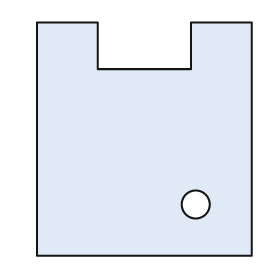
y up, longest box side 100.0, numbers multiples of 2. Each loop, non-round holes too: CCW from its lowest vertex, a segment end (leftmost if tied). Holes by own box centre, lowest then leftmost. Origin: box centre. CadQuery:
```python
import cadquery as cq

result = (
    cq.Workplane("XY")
    .moveTo(-46.0, -50.0)
    .lineTo(46.0, -50.0)
    .lineTo(46.0, 50.0)
    .lineTo(20.0, 50.0)
    .lineTo(20.0, 30.0)
    .lineTo(-20.0, 30.0)
    .lineTo(-20.0, 50.0)
    .lineTo(-46.0, 50.0)
    .close()
    .moveTo(22.0, -28.0)
    .circle(6.0)
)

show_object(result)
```